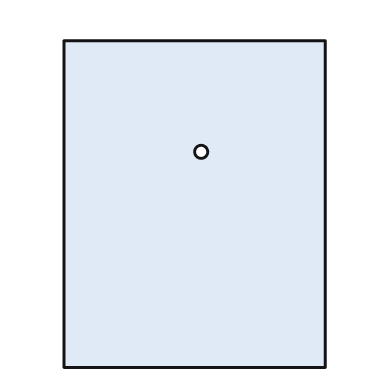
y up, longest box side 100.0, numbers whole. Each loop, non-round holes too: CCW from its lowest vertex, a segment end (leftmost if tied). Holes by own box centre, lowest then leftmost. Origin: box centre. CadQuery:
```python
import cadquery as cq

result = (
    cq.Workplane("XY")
    .moveTo(-40.0, -50.0)
    .lineTo(40.0, -50.0)
    .lineTo(40.0, 50.0)
    .lineTo(-40.0, 50.0)
    .close()
    .moveTo(2.0, 16.0)
    .circle(2.0)
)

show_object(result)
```